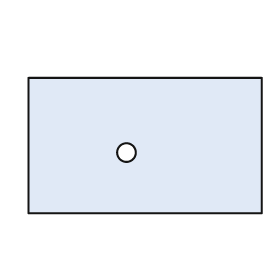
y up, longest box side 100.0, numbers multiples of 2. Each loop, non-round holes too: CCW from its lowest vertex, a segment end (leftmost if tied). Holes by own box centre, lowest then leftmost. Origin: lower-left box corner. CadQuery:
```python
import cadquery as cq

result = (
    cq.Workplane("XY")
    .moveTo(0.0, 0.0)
    .lineTo(100.0, 0.0)
    .lineTo(100.0, 58.0)
    .lineTo(0.0, 58.0)
    .close()
    .moveTo(42.0, 26.0)
    .circle(4.0)
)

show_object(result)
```